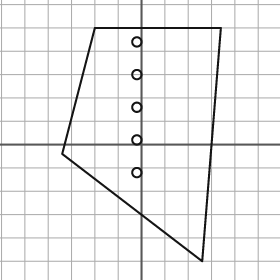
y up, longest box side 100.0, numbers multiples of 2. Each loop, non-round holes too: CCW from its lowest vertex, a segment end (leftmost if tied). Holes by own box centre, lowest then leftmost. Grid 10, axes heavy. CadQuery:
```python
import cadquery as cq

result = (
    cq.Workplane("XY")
    .moveTo(26.0, -50.0)
    .lineTo(34.0, 50.0)
    .lineTo(-20.0, 50.0)
    .lineTo(-34.0, -4.0)
    .close()
    .moveTo(-2.0, -12.0)
    .circle(2.0)
    .moveTo(-2.0, 2.0)
    .circle(2.0)
    .moveTo(-2.0, 16.0)
    .circle(2.0)
    .moveTo(-2.0, 30.0)
    .circle(2.0)
    .moveTo(-2.0, 44.0)
    .circle(2.0)
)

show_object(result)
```